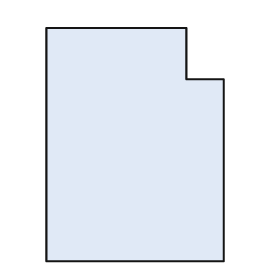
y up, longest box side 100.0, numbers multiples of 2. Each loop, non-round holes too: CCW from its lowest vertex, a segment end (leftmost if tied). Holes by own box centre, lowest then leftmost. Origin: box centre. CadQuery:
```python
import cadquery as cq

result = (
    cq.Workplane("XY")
    .moveTo(-38.0, -50.0)
    .lineTo(38.0, -50.0)
    .lineTo(38.0, 28.0)
    .lineTo(22.0, 28.0)
    .lineTo(22.0, 50.0)
    .lineTo(-38.0, 50.0)
    .close()
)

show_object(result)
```